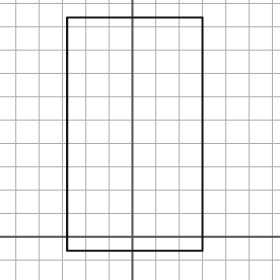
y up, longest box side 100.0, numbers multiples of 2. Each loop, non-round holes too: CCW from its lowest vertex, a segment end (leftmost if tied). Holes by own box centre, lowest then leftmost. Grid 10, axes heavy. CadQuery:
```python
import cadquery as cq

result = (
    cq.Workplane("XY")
    .moveTo(-28.0, -6.0)
    .lineTo(30.0, -6.0)
    .lineTo(30.0, 94.0)
    .lineTo(-28.0, 94.0)
    .close()
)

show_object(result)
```